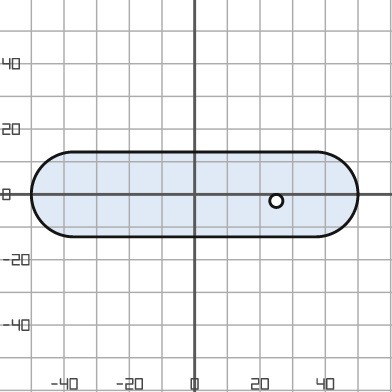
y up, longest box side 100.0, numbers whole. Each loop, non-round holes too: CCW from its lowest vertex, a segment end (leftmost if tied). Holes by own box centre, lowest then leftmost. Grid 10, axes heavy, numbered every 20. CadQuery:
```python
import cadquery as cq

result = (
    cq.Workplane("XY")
    .moveTo(-37.0, -13.0)
    .lineTo(37.0, -13.0)
    .threePointArc((50.0, 0.0), (37.0, 13.0))
    .lineTo(-37.0, 13.0)
    .threePointArc((-50.0, 0.0), (-37.0, -13.0))
    .close()
    .moveTo(25.0, -2.0)
    .circle(2.0)
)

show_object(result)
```